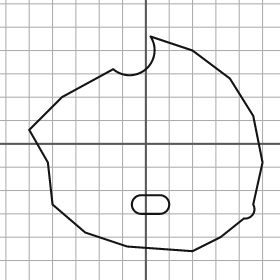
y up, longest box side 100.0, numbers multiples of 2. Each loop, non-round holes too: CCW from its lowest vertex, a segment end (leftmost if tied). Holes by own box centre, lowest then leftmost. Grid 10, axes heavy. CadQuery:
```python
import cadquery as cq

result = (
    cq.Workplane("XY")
    .moveTo(20.0, -46.0)
    .lineTo(32.0, -40.0)
    .lineTo(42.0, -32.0)
    .threePointArc((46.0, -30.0), (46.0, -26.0))
    .lineTo(50.0, -8.0)
    .lineTo(46.0, 12.0)
    .lineTo(36.0, 28.0)
    .lineTo(20.0, 40.0)
    .lineTo(2.0, 46.0)
    .threePointArc((0.0, 32.0), (-14.0, 32.0))
    .lineTo(-36.0, 20.0)
    .lineTo(-50.0, 6.0)
    .lineTo(-42.0, -8.0)
    .lineTo(-40.0, -26.0)
    .lineTo(-26.0, -38.0)
    .lineTo(-8.0, -44.0)
    .close()
    .moveTo(-2.0, -30.0)
    .lineTo(6.0, -30.0)
    .threePointArc((10.0, -26.0), (6.0, -22.0))
    .lineTo(-2.0, -22.0)
    .threePointArc((-6.0, -26.0), (-2.0, -30.0))
    .close()
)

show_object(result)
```